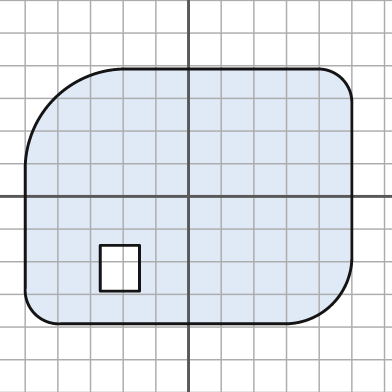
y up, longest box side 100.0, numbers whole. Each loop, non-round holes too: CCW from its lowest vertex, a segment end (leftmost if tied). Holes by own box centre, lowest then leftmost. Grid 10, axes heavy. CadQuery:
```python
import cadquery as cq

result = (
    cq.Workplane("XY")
    .moveTo(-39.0, -39.0)
    .lineTo(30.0, -39.0)
    .threePointArc((44.0, -33.0), (50.0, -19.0))
    .lineTo(50.0, 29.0)
    .threePointArc((47.0, 36.0), (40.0, 39.0))
    .lineTo(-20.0, 39.0)
    .threePointArc((-41.0, 30.0), (-50.0, 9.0))
    .lineTo(-50.0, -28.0)
    .threePointArc((-47.0, -36.0), (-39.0, -39.0))
    .close()
    .moveTo(-27.0, -29.0)
    .lineTo(-15.0, -29.0)
    .lineTo(-15.0, -15.0)
    .lineTo(-27.0, -15.0)
    .close()
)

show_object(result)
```